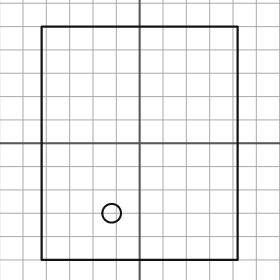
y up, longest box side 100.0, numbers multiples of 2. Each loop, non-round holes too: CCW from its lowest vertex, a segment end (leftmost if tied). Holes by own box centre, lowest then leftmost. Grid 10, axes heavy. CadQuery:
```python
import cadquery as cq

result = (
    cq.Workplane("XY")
    .moveTo(-42.0, -50.0)
    .lineTo(42.0, -50.0)
    .lineTo(42.0, 50.0)
    .lineTo(-42.0, 50.0)
    .close()
    .moveTo(-12.0, -30.0)
    .circle(4.0)
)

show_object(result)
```